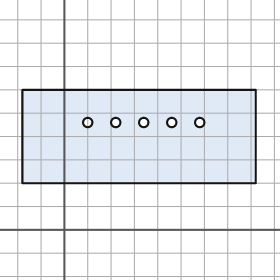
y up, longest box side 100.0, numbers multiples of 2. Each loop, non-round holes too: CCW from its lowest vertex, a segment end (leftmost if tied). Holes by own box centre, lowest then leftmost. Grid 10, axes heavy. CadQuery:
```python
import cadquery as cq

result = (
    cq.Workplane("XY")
    .moveTo(-18.0, 20.0)
    .lineTo(82.0, 20.0)
    .lineTo(82.0, 60.0)
    .lineTo(-18.0, 60.0)
    .close()
    .moveTo(10.0, 46.0)
    .circle(2.0)
    .moveTo(22.0, 46.0)
    .circle(2.0)
    .moveTo(34.0, 46.0)
    .circle(2.0)
    .moveTo(46.0, 46.0)
    .circle(2.0)
    .moveTo(58.0, 46.0)
    .circle(2.0)
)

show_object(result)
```